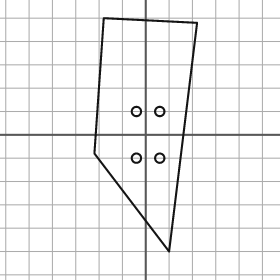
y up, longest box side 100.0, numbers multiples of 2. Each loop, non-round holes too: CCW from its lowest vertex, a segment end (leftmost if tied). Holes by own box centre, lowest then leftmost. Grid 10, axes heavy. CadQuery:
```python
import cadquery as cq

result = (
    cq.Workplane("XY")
    .moveTo(10.0, -50.0)
    .lineTo(22.0, 48.0)
    .lineTo(-18.0, 50.0)
    .lineTo(-22.0, -8.0)
    .close()
    .moveTo(-4.0, -10.0)
    .circle(2.0)
    .moveTo(6.0, -10.0)
    .circle(2.0)
    .moveTo(-4.0, 10.0)
    .circle(2.0)
    .moveTo(6.0, 10.0)
    .circle(2.0)
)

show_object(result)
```